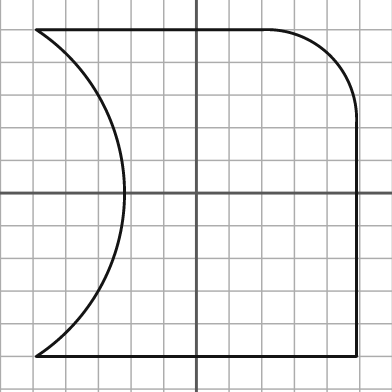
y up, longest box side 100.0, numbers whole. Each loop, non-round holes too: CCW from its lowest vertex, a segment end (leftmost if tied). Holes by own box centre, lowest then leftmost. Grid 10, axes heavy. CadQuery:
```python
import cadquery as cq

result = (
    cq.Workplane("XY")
    .moveTo(-49.0, -50.0)
    .lineTo(49.0, -50.0)
    .lineTo(49.0, 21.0)
    .threePointArc((41.0, 42.0), (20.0, 50.0))
    .lineTo(-49.0, 50.0)
    .threePointArc((-22.0, 0.0), (-49.0, -50.0))
    .close()
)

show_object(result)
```